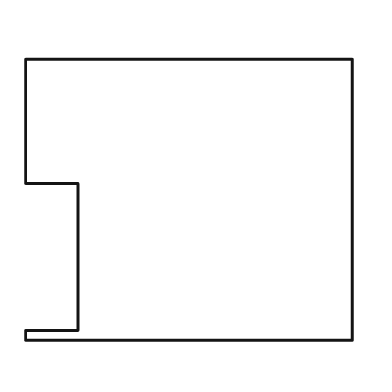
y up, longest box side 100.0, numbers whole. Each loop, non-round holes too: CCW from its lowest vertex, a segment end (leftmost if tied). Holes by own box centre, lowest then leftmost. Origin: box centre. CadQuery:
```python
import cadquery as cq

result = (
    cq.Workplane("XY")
    .moveTo(-50.0, -43.0)
    .lineTo(50.0, -43.0)
    .lineTo(50.0, 43.0)
    .lineTo(-50.0, 43.0)
    .lineTo(-50.0, 5.0)
    .lineTo(-34.0, 5.0)
    .lineTo(-34.0, -40.0)
    .lineTo(-50.0, -40.0)
    .close()
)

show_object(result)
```